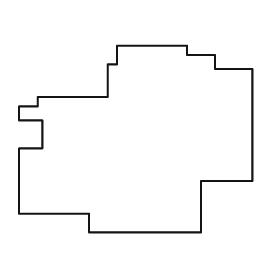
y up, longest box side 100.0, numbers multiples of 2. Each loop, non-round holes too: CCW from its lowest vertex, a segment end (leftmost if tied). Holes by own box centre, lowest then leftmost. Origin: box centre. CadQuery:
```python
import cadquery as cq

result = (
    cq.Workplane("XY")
    .moveTo(-20.0, -40.0)
    .lineTo(28.0, -40.0)
    .lineTo(28.0, -18.0)
    .lineTo(50.0, -18.0)
    .lineTo(50.0, 30.0)
    .lineTo(34.0, 30.0)
    .lineTo(34.0, 36.0)
    .lineTo(22.0, 36.0)
    .lineTo(22.0, 40.0)
    .lineTo(-8.0, 40.0)
    .lineTo(-8.0, 32.0)
    .lineTo(-12.0, 32.0)
    .lineTo(-12.0, 18.0)
    .lineTo(-42.0, 18.0)
    .lineTo(-42.0, 14.0)
    .lineTo(-50.0, 14.0)
    .lineTo(-50.0, 8.0)
    .lineTo(-40.0, 8.0)
    .lineTo(-40.0, -4.0)
    .lineTo(-50.0, -4.0)
    .lineTo(-50.0, -32.0)
    .lineTo(-20.0, -32.0)
    .close()
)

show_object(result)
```